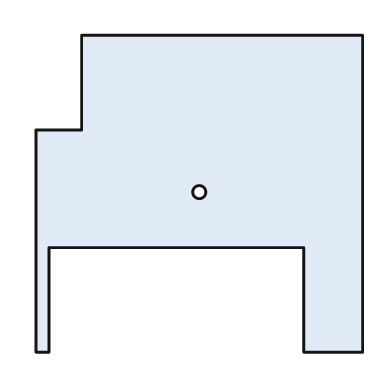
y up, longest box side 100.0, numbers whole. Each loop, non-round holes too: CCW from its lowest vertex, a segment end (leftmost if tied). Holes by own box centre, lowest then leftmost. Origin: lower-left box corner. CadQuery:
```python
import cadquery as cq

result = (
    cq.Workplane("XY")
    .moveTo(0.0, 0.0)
    .lineTo(4.0, 0.0)
    .lineTo(4.0, 32.0)
    .lineTo(82.0, 32.0)
    .lineTo(82.0, 0.0)
    .lineTo(100.0, 0.0)
    .lineTo(100.0, 97.0)
    .lineTo(14.0, 97.0)
    .lineTo(14.0, 68.0)
    .lineTo(0.0, 68.0)
    .close()
    .moveTo(50.0, 49.0)
    .circle(2.0)
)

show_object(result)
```